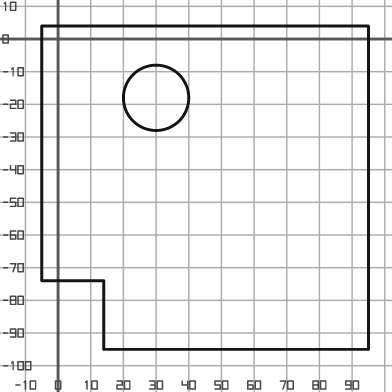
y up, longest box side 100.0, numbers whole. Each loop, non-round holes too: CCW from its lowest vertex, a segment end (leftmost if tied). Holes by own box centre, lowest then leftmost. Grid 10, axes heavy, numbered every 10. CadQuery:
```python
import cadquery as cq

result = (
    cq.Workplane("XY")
    .moveTo(14.0, -95.0)
    .lineTo(95.0, -95.0)
    .lineTo(95.0, 4.0)
    .lineTo(-5.0, 4.0)
    .lineTo(-5.0, -74.0)
    .lineTo(14.0, -74.0)
    .close()
    .moveTo(30.0, -18.0)
    .circle(10.0)
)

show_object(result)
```